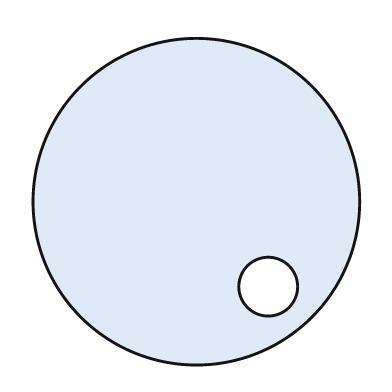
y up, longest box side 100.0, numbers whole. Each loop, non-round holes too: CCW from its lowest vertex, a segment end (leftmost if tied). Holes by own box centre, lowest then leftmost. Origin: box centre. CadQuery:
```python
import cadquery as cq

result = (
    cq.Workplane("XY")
    .moveTo(0.0, 0.0)
    .circle(50.0)
    .moveTo(22.0, -26.0)
    .circle(9.0)
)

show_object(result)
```